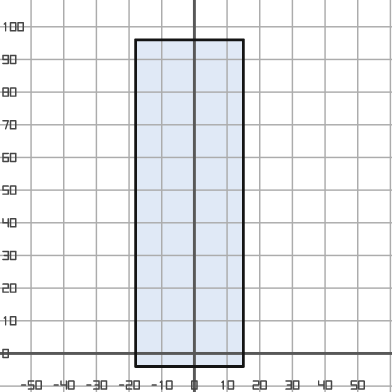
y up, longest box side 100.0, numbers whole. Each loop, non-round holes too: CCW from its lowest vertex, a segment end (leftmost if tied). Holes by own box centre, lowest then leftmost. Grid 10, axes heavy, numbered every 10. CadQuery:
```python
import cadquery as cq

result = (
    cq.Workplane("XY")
    .moveTo(-18.0, -4.0)
    .lineTo(15.0, -4.0)
    .lineTo(15.0, 96.0)
    .lineTo(-18.0, 96.0)
    .close()
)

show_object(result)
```